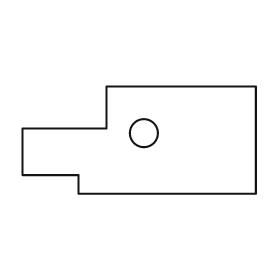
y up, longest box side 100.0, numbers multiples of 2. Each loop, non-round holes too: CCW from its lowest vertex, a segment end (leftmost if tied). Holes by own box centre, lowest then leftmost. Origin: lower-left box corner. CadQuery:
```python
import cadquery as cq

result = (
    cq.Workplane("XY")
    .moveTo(24.0, 0.0)
    .lineTo(100.0, 0.0)
    .lineTo(100.0, 46.0)
    .lineTo(36.0, 46.0)
    .lineTo(36.0, 28.0)
    .lineTo(0.0, 28.0)
    .lineTo(0.0, 8.0)
    .lineTo(24.0, 8.0)
    .close()
    .moveTo(52.0, 26.0)
    .circle(6.0)
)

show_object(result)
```